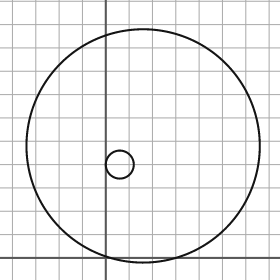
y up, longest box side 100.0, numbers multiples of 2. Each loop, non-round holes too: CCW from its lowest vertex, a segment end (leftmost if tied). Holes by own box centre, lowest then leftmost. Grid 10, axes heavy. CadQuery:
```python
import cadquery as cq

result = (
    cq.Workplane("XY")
    .moveTo(16.0, 48.0)
    .circle(50.0)
    .moveTo(6.0, 40.0)
    .circle(6.0)
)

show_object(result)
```